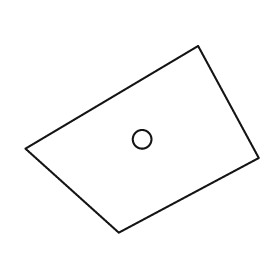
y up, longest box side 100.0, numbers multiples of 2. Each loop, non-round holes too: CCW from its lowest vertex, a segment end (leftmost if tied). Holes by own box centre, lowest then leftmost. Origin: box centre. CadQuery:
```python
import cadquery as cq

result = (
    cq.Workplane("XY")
    .moveTo(-10.0, -40.0)
    .lineTo(50.0, -8.0)
    .lineTo(24.0, 40.0)
    .lineTo(-50.0, -4.0)
    .close()
    .moveTo(0.0, 0.0)
    .circle(4.0)
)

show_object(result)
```